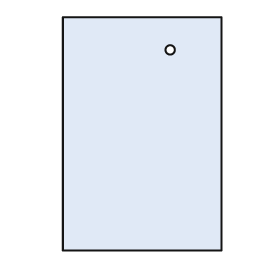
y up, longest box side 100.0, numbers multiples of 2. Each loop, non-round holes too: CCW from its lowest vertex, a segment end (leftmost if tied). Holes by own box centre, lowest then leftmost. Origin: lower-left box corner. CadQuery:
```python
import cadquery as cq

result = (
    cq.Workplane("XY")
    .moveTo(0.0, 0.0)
    .lineTo(68.0, 0.0)
    .lineTo(68.0, 100.0)
    .lineTo(0.0, 100.0)
    .close()
    .moveTo(46.0, 86.0)
    .circle(2.0)
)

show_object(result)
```